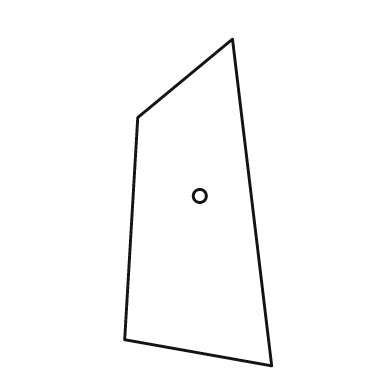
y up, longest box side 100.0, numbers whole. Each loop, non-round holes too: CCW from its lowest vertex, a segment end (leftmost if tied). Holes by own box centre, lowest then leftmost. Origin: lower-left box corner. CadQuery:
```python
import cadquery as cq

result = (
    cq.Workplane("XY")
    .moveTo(45.0, 0.0)
    .lineTo(33.0, 100.0)
    .lineTo(4.0, 76.0)
    .lineTo(0.0, 8.0)
    .close()
    .moveTo(23.0, 52.0)
    .circle(2.0)
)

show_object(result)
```